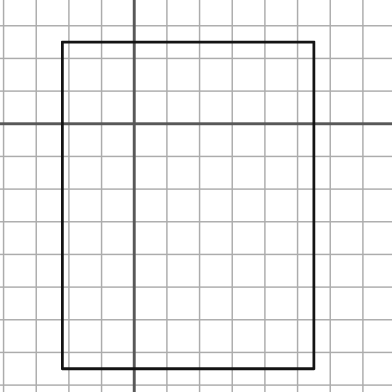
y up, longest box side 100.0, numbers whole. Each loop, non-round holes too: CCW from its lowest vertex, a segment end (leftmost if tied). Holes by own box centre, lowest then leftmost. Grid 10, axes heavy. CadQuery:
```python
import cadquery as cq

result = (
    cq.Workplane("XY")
    .moveTo(-22.0, -75.0)
    .lineTo(55.0, -75.0)
    .lineTo(55.0, 25.0)
    .lineTo(-22.0, 25.0)
    .close()
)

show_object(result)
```